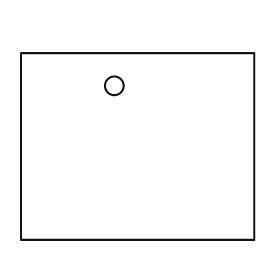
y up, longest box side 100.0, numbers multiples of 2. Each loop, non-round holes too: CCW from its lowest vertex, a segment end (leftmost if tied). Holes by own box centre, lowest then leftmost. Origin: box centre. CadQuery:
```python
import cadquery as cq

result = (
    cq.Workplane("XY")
    .moveTo(-50.0, -40.0)
    .lineTo(50.0, -40.0)
    .lineTo(50.0, 40.0)
    .lineTo(-50.0, 40.0)
    .close()
    .moveTo(-10.0, 26.0)
    .circle(4.0)
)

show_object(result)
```